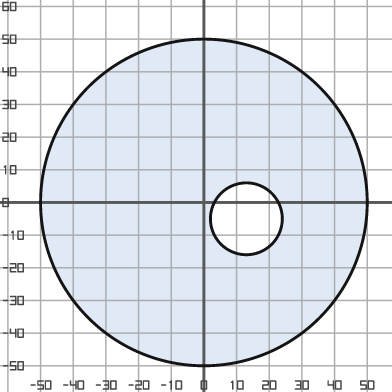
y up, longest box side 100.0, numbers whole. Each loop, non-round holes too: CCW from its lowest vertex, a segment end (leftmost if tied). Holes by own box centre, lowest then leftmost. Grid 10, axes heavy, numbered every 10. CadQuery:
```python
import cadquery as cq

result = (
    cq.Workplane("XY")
    .moveTo(0.0, 0.0)
    .circle(50.0)
    .moveTo(13.0, -5.0)
    .circle(11.0)
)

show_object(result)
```